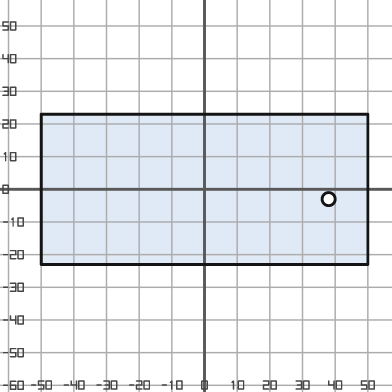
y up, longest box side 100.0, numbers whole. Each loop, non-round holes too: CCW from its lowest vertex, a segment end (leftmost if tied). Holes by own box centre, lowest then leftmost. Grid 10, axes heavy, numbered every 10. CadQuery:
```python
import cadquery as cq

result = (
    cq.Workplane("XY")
    .moveTo(-50.0, -23.0)
    .lineTo(50.0, -23.0)
    .lineTo(50.0, 23.0)
    .lineTo(-50.0, 23.0)
    .close()
    .moveTo(38.0, -3.0)
    .circle(2.0)
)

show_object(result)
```